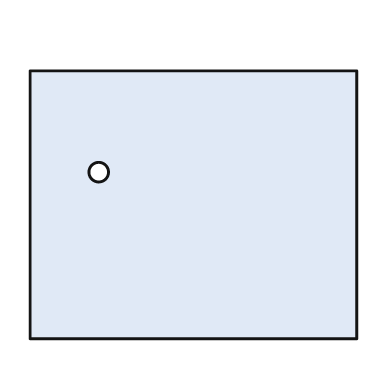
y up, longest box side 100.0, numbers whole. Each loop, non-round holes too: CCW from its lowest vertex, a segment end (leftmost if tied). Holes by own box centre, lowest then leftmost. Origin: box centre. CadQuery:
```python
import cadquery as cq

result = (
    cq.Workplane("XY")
    .moveTo(-50.0, -41.0)
    .lineTo(50.0, -41.0)
    .lineTo(50.0, 41.0)
    .lineTo(-50.0, 41.0)
    .close()
    .moveTo(-29.0, 10.0)
    .circle(3.0)
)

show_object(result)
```